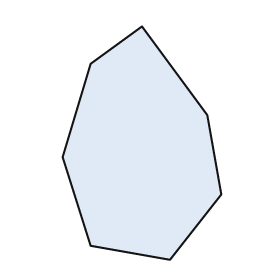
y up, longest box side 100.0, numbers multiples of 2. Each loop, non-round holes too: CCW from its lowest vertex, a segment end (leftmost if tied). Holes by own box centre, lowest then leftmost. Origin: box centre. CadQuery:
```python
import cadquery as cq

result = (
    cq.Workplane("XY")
    .moveTo(12.0, -50.0)
    .lineTo(34.0, -22.0)
    .lineTo(28.0, 12.0)
    .lineTo(0.0, 50.0)
    .lineTo(-22.0, 34.0)
    .lineTo(-34.0, -6.0)
    .lineTo(-22.0, -44.0)
    .close()
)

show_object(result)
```